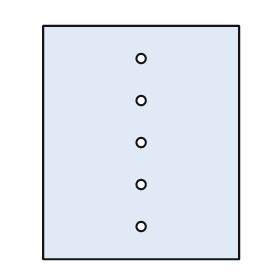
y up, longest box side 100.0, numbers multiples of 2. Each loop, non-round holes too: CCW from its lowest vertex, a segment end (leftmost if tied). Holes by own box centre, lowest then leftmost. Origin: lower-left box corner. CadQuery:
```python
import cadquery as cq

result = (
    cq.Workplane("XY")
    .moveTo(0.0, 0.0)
    .lineTo(84.0, 0.0)
    .lineTo(84.0, 100.0)
    .lineTo(0.0, 100.0)
    .close()
    .moveTo(42.0, 14.0)
    .circle(2.0)
    .moveTo(42.0, 32.0)
    .circle(2.0)
    .moveTo(42.0, 50.0)
    .circle(2.0)
    .moveTo(42.0, 68.0)
    .circle(2.0)
    .moveTo(42.0, 86.0)
    .circle(2.0)
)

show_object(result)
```